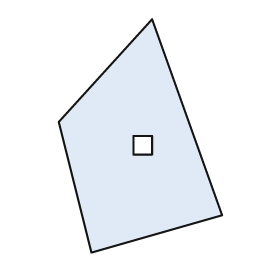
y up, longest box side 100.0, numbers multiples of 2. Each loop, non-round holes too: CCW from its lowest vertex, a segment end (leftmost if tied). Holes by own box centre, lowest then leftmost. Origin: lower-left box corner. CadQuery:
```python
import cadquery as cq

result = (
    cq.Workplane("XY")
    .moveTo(14.0, 0.0)
    .lineTo(70.0, 16.0)
    .lineTo(40.0, 100.0)
    .lineTo(0.0, 56.0)
    .close()
    .moveTo(32.0, 42.0)
    .lineTo(40.0, 42.0)
    .lineTo(40.0, 50.0)
    .lineTo(32.0, 50.0)
    .close()
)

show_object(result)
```